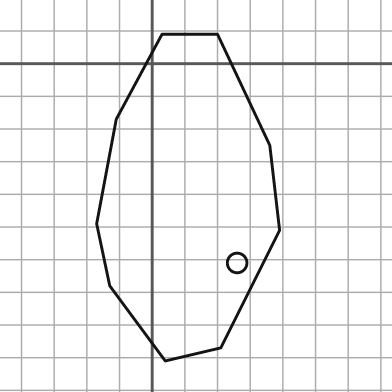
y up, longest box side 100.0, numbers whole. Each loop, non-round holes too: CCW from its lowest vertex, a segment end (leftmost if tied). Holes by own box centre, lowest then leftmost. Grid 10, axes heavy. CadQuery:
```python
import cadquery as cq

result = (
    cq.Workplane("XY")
    .moveTo(4.0, -91.0)
    .lineTo(21.0, -87.0)
    .lineTo(39.0, -51.0)
    .lineTo(36.0, -25.0)
    .lineTo(20.0, 9.0)
    .lineTo(3.0, 9.0)
    .lineTo(-11.0, -17.0)
    .lineTo(-17.0, -49.0)
    .lineTo(-13.0, -68.0)
    .close()
    .moveTo(26.0, -61.0)
    .circle(3.0)
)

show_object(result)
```